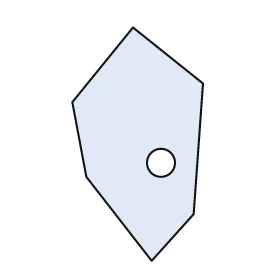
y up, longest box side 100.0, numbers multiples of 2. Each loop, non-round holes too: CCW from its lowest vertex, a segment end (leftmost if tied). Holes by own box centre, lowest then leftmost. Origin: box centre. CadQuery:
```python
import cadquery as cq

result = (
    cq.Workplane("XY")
    .moveTo(6.0, -50.0)
    .lineTo(24.0, -30.0)
    .lineTo(28.0, 26.0)
    .lineTo(-2.0, 50.0)
    .lineTo(-28.0, 18.0)
    .lineTo(-22.0, -14.0)
    .close()
    .moveTo(10.0, -8.0)
    .circle(6.0)
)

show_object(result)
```